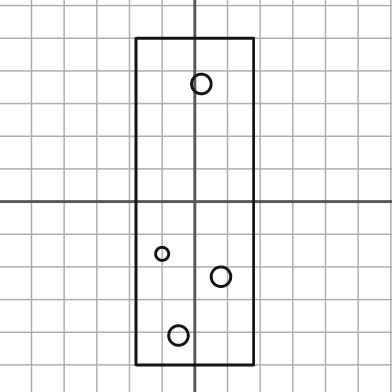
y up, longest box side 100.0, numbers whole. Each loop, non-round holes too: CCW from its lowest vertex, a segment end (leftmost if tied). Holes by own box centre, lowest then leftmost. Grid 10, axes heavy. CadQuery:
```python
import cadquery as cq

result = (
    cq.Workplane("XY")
    .moveTo(-18.0, -50.0)
    .lineTo(18.0, -50.0)
    .lineTo(18.0, 50.0)
    .lineTo(-18.0, 50.0)
    .close()
    .moveTo(-5.0, -41.0)
    .circle(3.0)
    .moveTo(8.0, -23.0)
    .circle(3.0)
    .moveTo(-10.0, -16.0)
    .circle(2.0)
    .moveTo(2.0, 36.0)
    .circle(3.0)
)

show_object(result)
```